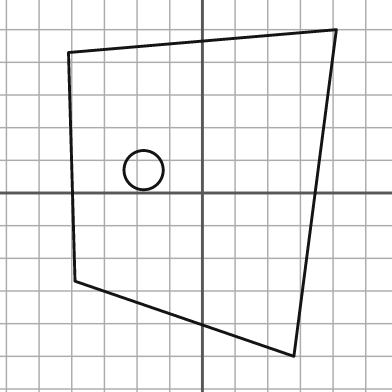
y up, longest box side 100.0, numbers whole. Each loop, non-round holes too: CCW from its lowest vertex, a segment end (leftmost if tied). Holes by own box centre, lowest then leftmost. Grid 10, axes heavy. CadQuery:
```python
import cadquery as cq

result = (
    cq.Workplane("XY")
    .moveTo(28.0, -50.0)
    .lineTo(41.0, 50.0)
    .lineTo(-41.0, 43.0)
    .lineTo(-39.0, -27.0)
    .close()
    .moveTo(-18.0, 7.0)
    .circle(6.0)
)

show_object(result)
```